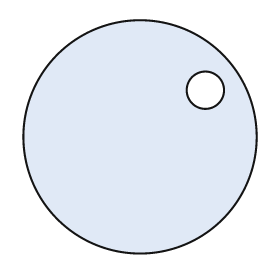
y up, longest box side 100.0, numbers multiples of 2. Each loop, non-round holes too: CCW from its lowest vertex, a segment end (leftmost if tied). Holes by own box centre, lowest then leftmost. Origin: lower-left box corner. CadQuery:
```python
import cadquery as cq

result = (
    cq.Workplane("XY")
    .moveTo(50.0, 50.0)
    .circle(50.0)
    .moveTo(78.0, 70.0)
    .circle(8.0)
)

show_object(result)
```